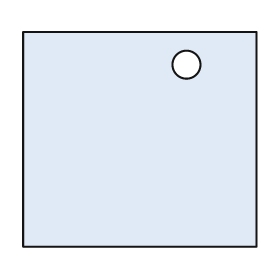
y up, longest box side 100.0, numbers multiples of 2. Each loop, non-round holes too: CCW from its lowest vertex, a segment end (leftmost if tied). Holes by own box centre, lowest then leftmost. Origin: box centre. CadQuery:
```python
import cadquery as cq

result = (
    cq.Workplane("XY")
    .moveTo(-50.0, -46.0)
    .lineTo(50.0, -46.0)
    .lineTo(50.0, 46.0)
    .lineTo(-50.0, 46.0)
    .close()
    .moveTo(20.0, 32.0)
    .circle(6.0)
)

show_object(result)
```